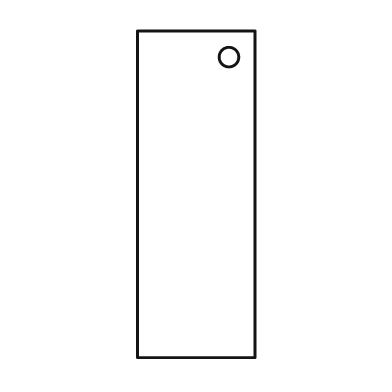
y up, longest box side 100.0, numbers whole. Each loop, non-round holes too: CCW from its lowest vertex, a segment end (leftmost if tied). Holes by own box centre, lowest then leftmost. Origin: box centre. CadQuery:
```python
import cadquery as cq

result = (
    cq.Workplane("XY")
    .moveTo(-18.0, -50.0)
    .lineTo(18.0, -50.0)
    .lineTo(18.0, 50.0)
    .lineTo(-18.0, 50.0)
    .close()
    .moveTo(10.0, 42.0)
    .circle(3.0)
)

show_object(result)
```